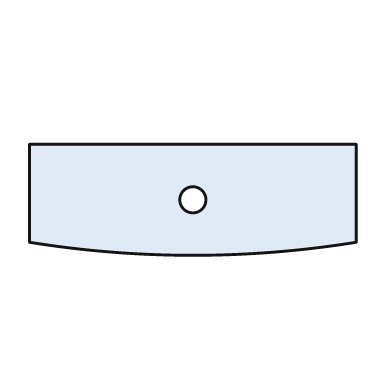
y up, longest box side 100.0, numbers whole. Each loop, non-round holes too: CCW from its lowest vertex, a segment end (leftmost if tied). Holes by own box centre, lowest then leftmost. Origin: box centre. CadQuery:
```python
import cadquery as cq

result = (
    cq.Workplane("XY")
    .moveTo(-50.0, -13.0)
    .threePointArc((0.0, -17.0), (50.0, -13.0))
    .lineTo(50.0, 17.0)
    .lineTo(-50.0, 17.0)
    .close()
    .moveTo(0.0, 0.0)
    .circle(4.0)
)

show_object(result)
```